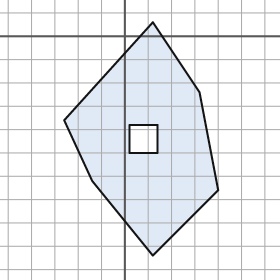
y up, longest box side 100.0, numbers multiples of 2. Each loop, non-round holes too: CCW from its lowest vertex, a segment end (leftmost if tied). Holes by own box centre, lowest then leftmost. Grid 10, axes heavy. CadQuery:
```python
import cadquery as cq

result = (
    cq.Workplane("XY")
    .moveTo(12.0, -94.0)
    .lineTo(40.0, -66.0)
    .lineTo(32.0, -24.0)
    .lineTo(12.0, 6.0)
    .lineTo(-26.0, -36.0)
    .lineTo(-14.0, -62.0)
    .close()
    .moveTo(2.0, -50.0)
    .lineTo(14.0, -50.0)
    .lineTo(14.0, -38.0)
    .lineTo(2.0, -38.0)
    .close()
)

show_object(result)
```